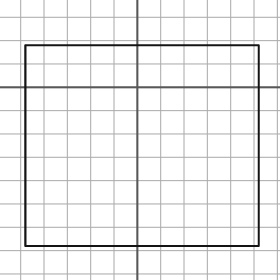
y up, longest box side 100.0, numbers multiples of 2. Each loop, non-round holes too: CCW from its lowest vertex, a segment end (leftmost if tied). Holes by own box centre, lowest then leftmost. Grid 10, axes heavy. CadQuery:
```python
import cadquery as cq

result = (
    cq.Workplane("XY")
    .moveTo(-48.0, -68.0)
    .lineTo(52.0, -68.0)
    .lineTo(52.0, 18.0)
    .lineTo(-48.0, 18.0)
    .close()
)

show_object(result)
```